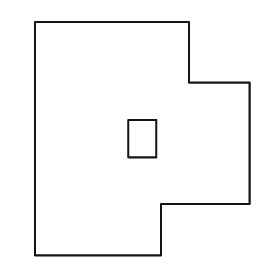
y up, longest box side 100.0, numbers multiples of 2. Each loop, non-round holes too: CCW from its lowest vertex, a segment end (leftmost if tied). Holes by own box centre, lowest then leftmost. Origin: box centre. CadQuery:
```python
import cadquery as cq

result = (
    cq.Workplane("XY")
    .moveTo(-46.0, -50.0)
    .lineTo(8.0, -50.0)
    .lineTo(8.0, -28.0)
    .lineTo(46.0, -28.0)
    .lineTo(46.0, 24.0)
    .lineTo(20.0, 24.0)
    .lineTo(20.0, 50.0)
    .lineTo(-46.0, 50.0)
    .close()
    .moveTo(-6.0, -8.0)
    .lineTo(6.0, -8.0)
    .lineTo(6.0, 8.0)
    .lineTo(-6.0, 8.0)
    .close()
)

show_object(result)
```